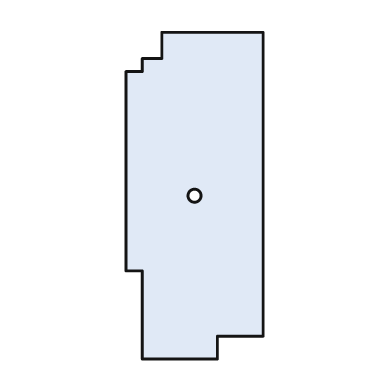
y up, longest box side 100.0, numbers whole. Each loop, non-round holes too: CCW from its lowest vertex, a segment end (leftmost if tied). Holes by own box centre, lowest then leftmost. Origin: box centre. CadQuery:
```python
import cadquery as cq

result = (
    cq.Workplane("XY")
    .moveTo(-16.0, -50.0)
    .lineTo(7.0, -50.0)
    .lineTo(7.0, -43.0)
    .lineTo(21.0, -43.0)
    .lineTo(21.0, 50.0)
    .lineTo(-10.0, 50.0)
    .lineTo(-10.0, 42.0)
    .lineTo(-16.0, 42.0)
    .lineTo(-16.0, 38.0)
    .lineTo(-21.0, 38.0)
    .lineTo(-21.0, -23.0)
    .lineTo(-16.0, -23.0)
    .close()
    .moveTo(0.0, 0.0)
    .circle(2.0)
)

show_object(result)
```